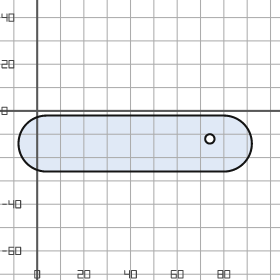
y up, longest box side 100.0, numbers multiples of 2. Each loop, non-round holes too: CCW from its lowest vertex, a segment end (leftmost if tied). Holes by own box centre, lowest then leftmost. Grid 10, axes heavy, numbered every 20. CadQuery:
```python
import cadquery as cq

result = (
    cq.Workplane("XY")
    .moveTo(4.0, -26.0)
    .lineTo(80.0, -26.0)
    .threePointArc((92.0, -14.0), (80.0, -2.0))
    .lineTo(4.0, -2.0)
    .threePointArc((-8.0, -14.0), (4.0, -26.0))
    .close()
    .moveTo(74.0, -12.0)
    .circle(2.0)
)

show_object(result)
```